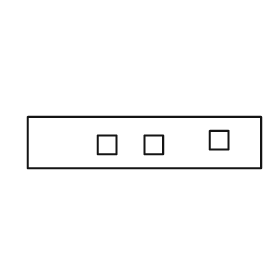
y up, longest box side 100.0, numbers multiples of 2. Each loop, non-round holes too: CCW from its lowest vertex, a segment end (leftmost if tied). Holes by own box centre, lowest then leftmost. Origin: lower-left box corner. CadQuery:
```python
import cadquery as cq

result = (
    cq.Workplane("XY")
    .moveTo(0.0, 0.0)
    .lineTo(100.0, 0.0)
    .lineTo(100.0, 22.0)
    .lineTo(0.0, 22.0)
    .close()
    .moveTo(30.0, 6.0)
    .lineTo(38.0, 6.0)
    .lineTo(38.0, 14.0)
    .lineTo(30.0, 14.0)
    .close()
    .moveTo(50.0, 6.0)
    .lineTo(58.0, 6.0)
    .lineTo(58.0, 14.0)
    .lineTo(50.0, 14.0)
    .close()
    .moveTo(78.0, 8.0)
    .lineTo(86.0, 8.0)
    .lineTo(86.0, 16.0)
    .lineTo(78.0, 16.0)
    .close()
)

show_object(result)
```